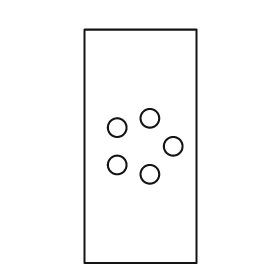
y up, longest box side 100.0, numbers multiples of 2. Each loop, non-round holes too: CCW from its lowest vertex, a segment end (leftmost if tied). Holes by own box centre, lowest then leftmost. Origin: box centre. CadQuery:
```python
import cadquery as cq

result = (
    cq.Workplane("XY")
    .moveTo(-24.0, -50.0)
    .lineTo(24.0, -50.0)
    .lineTo(24.0, 50.0)
    .lineTo(-24.0, 50.0)
    .close()
    .moveTo(4.0, -12.0)
    .circle(4.0)
    .moveTo(-10.0, -8.0)
    .circle(4.0)
    .moveTo(14.0, 0.0)
    .circle(4.0)
    .moveTo(-10.0, 8.0)
    .circle(4.0)
    .moveTo(4.0, 12.0)
    .circle(4.0)
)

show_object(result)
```